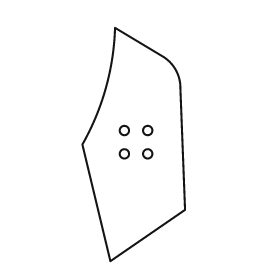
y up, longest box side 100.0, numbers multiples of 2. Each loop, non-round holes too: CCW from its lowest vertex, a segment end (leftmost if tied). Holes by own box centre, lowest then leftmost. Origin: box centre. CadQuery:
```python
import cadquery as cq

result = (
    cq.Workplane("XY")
    .moveTo(-10.0, -50.0)
    .lineTo(22.0, -28.0)
    .lineTo(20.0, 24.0)
    .threePointArc((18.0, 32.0), (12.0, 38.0))
    .lineTo(-8.0, 50.0)
    .threePointArc((-12.0, 24.0), (-22.0, 0.0))
    .close()
    .moveTo(-4.0, -4.0)
    .circle(2.0)
    .moveTo(6.0, -4.0)
    .circle(2.0)
    .moveTo(-4.0, 6.0)
    .circle(2.0)
    .moveTo(6.0, 6.0)
    .circle(2.0)
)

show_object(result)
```